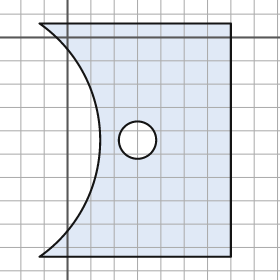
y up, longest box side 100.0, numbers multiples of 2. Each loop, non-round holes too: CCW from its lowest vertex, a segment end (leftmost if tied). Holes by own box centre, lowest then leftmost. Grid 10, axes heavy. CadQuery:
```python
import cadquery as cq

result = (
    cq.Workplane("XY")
    .moveTo(-12.0, -94.0)
    .lineTo(70.0, -94.0)
    .lineTo(70.0, 6.0)
    .lineTo(-12.0, 6.0)
    .threePointArc((14.0, -44.0), (-12.0, -94.0))
    .close()
    .moveTo(30.0, -44.0)
    .circle(8.0)
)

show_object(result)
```